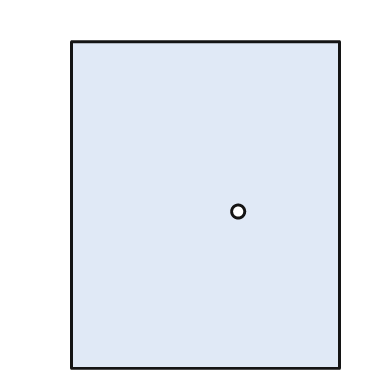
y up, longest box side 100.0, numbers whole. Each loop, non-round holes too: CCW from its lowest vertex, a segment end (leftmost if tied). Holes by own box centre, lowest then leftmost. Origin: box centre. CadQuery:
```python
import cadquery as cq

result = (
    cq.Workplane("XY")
    .moveTo(-41.0, -50.0)
    .lineTo(41.0, -50.0)
    .lineTo(41.0, 50.0)
    .lineTo(-41.0, 50.0)
    .close()
    .moveTo(10.0, -2.0)
    .circle(2.0)
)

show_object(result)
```